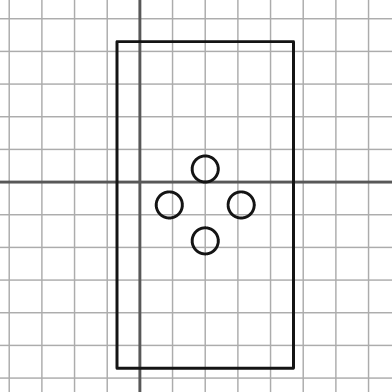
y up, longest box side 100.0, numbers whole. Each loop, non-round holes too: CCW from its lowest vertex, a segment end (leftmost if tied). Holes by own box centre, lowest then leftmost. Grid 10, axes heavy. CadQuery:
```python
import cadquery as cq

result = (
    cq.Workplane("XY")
    .moveTo(-7.0, -57.0)
    .lineTo(47.0, -57.0)
    .lineTo(47.0, 43.0)
    .lineTo(-7.0, 43.0)
    .close()
    .moveTo(20.0, -18.0)
    .circle(4.0)
    .moveTo(9.0, -7.0)
    .circle(4.0)
    .moveTo(31.0, -7.0)
    .circle(4.0)
    .moveTo(20.0, 4.0)
    .circle(4.0)
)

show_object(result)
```